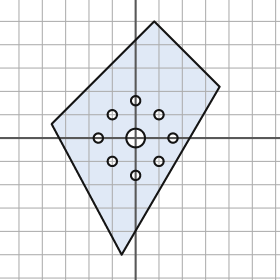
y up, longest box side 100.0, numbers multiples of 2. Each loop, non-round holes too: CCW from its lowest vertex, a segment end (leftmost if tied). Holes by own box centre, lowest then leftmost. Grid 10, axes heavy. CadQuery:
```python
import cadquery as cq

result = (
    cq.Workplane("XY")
    .moveTo(-6.0, -50.0)
    .lineTo(36.0, 22.0)
    .lineTo(8.0, 50.0)
    .lineTo(-36.0, 6.0)
    .close()
    .moveTo(0.0, -16.0)
    .circle(2.0)
    .moveTo(-10.0, -10.0)
    .circle(2.0)
    .moveTo(10.0, -10.0)
    .circle(2.0)
    .moveTo(-16.0, 0.0)
    .circle(2.0)
    .moveTo(0.0, 0.0)
    .circle(4.0)
    .moveTo(16.0, 0.0)
    .circle(2.0)
    .moveTo(-10.0, 10.0)
    .circle(2.0)
    .moveTo(10.0, 10.0)
    .circle(2.0)
    .moveTo(0.0, 16.0)
    .circle(2.0)
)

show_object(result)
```